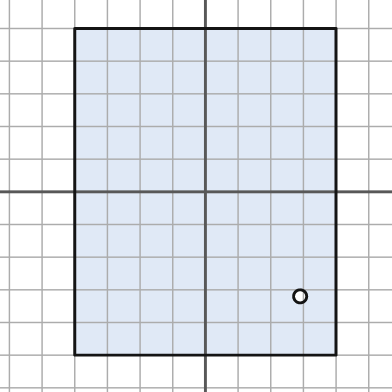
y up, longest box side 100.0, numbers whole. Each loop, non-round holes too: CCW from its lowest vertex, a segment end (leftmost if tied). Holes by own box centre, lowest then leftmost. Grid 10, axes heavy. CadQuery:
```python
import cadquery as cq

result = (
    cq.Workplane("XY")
    .moveTo(-40.0, -50.0)
    .lineTo(40.0, -50.0)
    .lineTo(40.0, 50.0)
    .lineTo(-40.0, 50.0)
    .close()
    .moveTo(29.0, -32.0)
    .circle(2.0)
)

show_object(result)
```